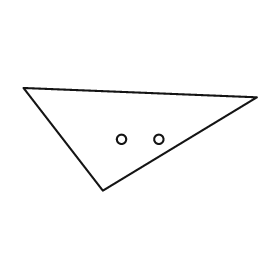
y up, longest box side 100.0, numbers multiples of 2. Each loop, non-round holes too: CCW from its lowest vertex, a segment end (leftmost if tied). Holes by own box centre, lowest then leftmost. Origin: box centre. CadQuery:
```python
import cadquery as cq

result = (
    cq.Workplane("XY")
    .moveTo(-16.0, -22.0)
    .lineTo(50.0, 18.0)
    .lineTo(-50.0, 22.0)
    .close()
    .moveTo(-8.0, 0.0)
    .circle(2.0)
    .moveTo(8.0, 0.0)
    .circle(2.0)
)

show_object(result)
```